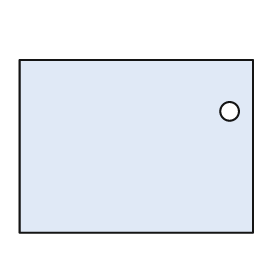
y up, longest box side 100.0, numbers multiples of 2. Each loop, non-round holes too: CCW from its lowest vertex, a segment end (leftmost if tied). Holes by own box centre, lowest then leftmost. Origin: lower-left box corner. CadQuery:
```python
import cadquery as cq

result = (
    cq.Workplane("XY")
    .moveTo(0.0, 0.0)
    .lineTo(100.0, 0.0)
    .lineTo(100.0, 74.0)
    .lineTo(0.0, 74.0)
    .close()
    .moveTo(90.0, 52.0)
    .circle(4.0)
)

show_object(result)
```